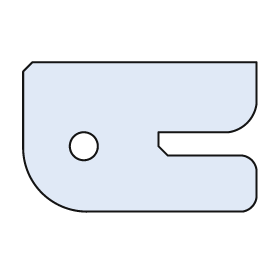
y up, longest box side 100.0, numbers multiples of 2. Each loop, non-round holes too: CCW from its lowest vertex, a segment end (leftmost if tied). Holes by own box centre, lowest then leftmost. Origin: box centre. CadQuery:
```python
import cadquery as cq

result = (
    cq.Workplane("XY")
    .moveTo(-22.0, -32.0)
    .lineTo(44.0, -32.0)
    .threePointArc((48.0, -30.0), (50.0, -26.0))
    .lineTo(50.0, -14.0)
    .threePointArc((48.0, -10.0), (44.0, -8.0))
    .lineTo(12.0, -8.0)
    .lineTo(8.0, -4.0)
    .lineTo(8.0, 2.0)
    .lineTo(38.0, 2.0)
    .threePointArc((46.0, 6.0), (50.0, 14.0))
    .lineTo(50.0, 32.0)
    .lineTo(-46.0, 32.0)
    .lineTo(-50.0, 28.0)
    .lineTo(-50.0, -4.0)
    .threePointArc((-42.0, -24.0), (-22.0, -32.0))
    .close()
    .moveTo(-24.0, -4.0)
    .circle(6.0)
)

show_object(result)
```